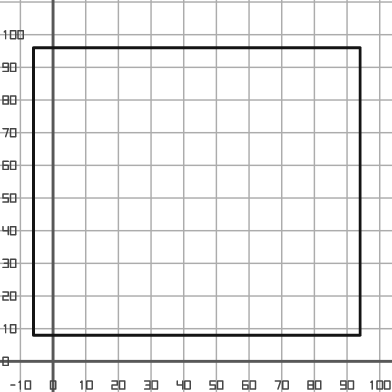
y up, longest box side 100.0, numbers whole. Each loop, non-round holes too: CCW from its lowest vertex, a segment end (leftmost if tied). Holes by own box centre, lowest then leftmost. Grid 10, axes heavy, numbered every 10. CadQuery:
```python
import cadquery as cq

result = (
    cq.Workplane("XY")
    .moveTo(-6.0, 8.0)
    .lineTo(94.0, 8.0)
    .lineTo(94.0, 96.0)
    .lineTo(-6.0, 96.0)
    .close()
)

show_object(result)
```